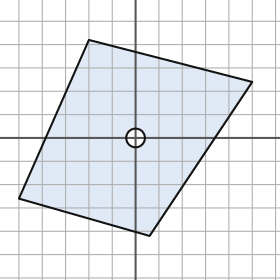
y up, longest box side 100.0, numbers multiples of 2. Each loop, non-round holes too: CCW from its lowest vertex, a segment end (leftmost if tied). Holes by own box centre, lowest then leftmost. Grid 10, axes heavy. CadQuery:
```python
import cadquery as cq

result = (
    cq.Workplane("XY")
    .moveTo(6.0, -42.0)
    .lineTo(50.0, 24.0)
    .lineTo(-20.0, 42.0)
    .lineTo(-50.0, -26.0)
    .close()
    .moveTo(0.0, 0.0)
    .circle(4.0)
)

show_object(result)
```